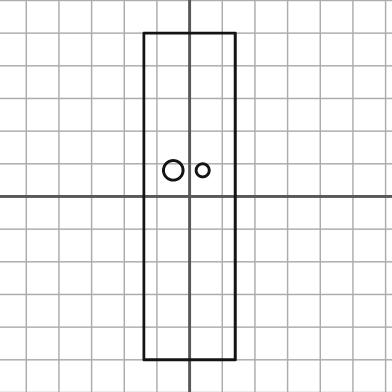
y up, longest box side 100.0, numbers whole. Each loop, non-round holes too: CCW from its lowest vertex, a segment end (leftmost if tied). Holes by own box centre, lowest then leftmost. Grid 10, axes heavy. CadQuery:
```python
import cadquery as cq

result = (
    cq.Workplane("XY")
    .moveTo(-14.0, -50.0)
    .lineTo(14.0, -50.0)
    .lineTo(14.0, 50.0)
    .lineTo(-14.0, 50.0)
    .close()
    .moveTo(-5.0, 8.0)
    .circle(3.0)
    .moveTo(4.0, 8.0)
    .circle(2.0)
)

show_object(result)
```